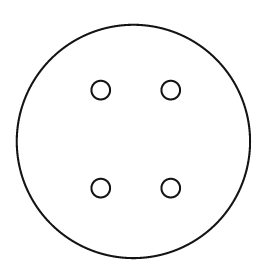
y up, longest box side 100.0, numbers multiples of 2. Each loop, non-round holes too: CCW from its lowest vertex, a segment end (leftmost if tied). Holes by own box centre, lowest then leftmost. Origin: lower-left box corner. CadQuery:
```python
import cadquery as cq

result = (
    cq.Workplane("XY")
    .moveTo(50.0, 50.0)
    .circle(50.0)
    .moveTo(36.0, 30.0)
    .circle(4.0)
    .moveTo(66.0, 30.0)
    .circle(4.0)
    .moveTo(36.0, 72.0)
    .circle(4.0)
    .moveTo(66.0, 72.0)
    .circle(4.0)
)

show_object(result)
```